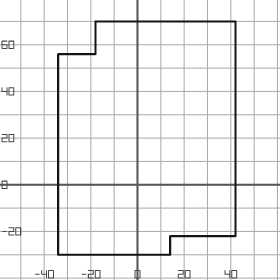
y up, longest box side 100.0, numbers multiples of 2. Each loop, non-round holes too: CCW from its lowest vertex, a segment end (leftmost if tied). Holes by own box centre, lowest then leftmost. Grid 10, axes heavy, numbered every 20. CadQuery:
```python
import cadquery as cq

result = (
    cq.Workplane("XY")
    .moveTo(-34.0, -30.0)
    .lineTo(14.0, -30.0)
    .lineTo(14.0, -22.0)
    .lineTo(42.0, -22.0)
    .lineTo(42.0, 70.0)
    .lineTo(-18.0, 70.0)
    .lineTo(-18.0, 56.0)
    .lineTo(-34.0, 56.0)
    .close()
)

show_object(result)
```